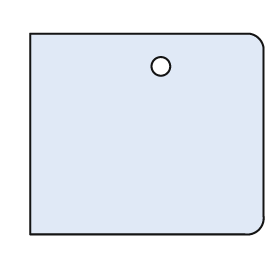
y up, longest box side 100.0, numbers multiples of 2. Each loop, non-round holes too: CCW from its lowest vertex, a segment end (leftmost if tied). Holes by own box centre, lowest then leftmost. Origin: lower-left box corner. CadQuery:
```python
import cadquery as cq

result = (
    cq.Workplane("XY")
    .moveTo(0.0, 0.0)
    .lineTo(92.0, 0.0)
    .threePointArc((98.0, 2.0), (100.0, 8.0))
    .lineTo(100.0, 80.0)
    .threePointArc((98.0, 84.0), (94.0, 86.0))
    .lineTo(0.0, 86.0)
    .close()
    .moveTo(56.0, 72.0)
    .circle(4.0)
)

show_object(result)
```